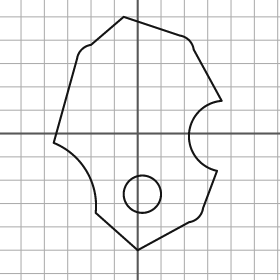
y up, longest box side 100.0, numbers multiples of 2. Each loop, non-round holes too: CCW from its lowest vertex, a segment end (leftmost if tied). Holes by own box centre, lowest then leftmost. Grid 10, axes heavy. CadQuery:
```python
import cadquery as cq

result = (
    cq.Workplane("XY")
    .moveTo(0.0, -50.0)
    .lineTo(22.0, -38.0)
    .threePointArc((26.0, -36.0), (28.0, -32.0))
    .lineTo(34.0, -16.0)
    .threePointArc((22.0, 0.0), (36.0, 14.0))
    .lineTo(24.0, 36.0)
    .threePointArc((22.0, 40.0), (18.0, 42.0))
    .lineTo(-6.0, 50.0)
    .lineTo(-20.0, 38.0)
    .threePointArc((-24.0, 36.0), (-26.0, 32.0))
    .lineTo(-36.0, -4.0)
    .threePointArc((-22.0, -16.0), (-18.0, -34.0))
    .close()
    .moveTo(2.0, -26.0)
    .circle(8.0)
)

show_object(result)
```